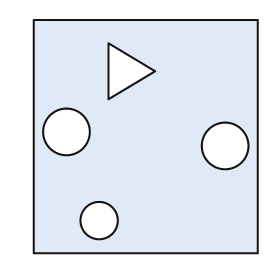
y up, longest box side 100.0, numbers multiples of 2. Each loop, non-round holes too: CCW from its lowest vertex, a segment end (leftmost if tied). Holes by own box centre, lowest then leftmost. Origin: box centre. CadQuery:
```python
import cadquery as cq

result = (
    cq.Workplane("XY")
    .moveTo(-48.0, -50.0)
    .lineTo(48.0, -50.0)
    .lineTo(48.0, 50.0)
    .lineTo(-48.0, 50.0)
    .close()
    .moveTo(-20.0, -36.0)
    .circle(8.0)
    .moveTo(34.0, -4.0)
    .circle(10.0)
    .moveTo(-34.0, 2.0)
    .circle(10.0)
    .moveTo(-16.0, 16.0)
    .lineTo(4.0, 28.0)
    .lineTo(-16.0, 40.0)
    .close()
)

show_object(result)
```